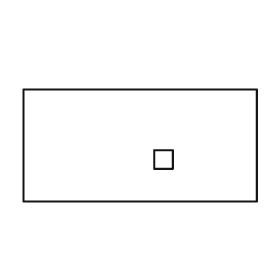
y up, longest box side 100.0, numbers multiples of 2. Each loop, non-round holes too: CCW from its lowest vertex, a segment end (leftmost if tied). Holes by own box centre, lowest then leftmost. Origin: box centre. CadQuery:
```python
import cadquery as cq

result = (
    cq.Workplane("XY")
    .moveTo(-50.0, -24.0)
    .lineTo(50.0, -24.0)
    .lineTo(50.0, 24.0)
    .lineTo(-50.0, 24.0)
    .close()
    .moveTo(6.0, -10.0)
    .lineTo(14.0, -10.0)
    .lineTo(14.0, -2.0)
    .lineTo(6.0, -2.0)
    .close()
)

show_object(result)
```